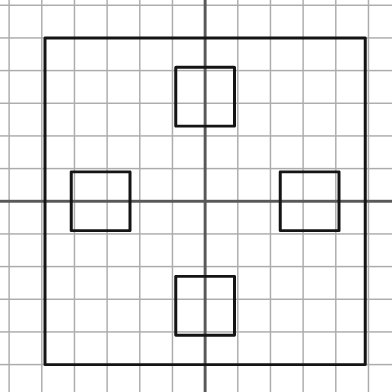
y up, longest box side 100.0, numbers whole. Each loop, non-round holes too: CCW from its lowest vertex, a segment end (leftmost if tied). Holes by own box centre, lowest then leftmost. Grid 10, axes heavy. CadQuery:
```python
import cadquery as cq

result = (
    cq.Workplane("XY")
    .moveTo(-49.0, -50.0)
    .lineTo(49.0, -50.0)
    .lineTo(49.0, 50.0)
    .lineTo(-49.0, 50.0)
    .close()
    .moveTo(-9.0, -41.0)
    .lineTo(9.0, -41.0)
    .lineTo(9.0, -23.0)
    .lineTo(-9.0, -23.0)
    .close()
    .moveTo(-41.0, -9.0)
    .lineTo(-23.0, -9.0)
    .lineTo(-23.0, 9.0)
    .lineTo(-41.0, 9.0)
    .close()
    .moveTo(23.0, -9.0)
    .lineTo(41.0, -9.0)
    .lineTo(41.0, 9.0)
    .lineTo(23.0, 9.0)
    .close()
    .moveTo(-9.0, 23.0)
    .lineTo(9.0, 23.0)
    .lineTo(9.0, 41.0)
    .lineTo(-9.0, 41.0)
    .close()
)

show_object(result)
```